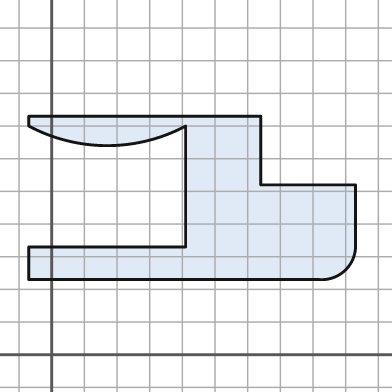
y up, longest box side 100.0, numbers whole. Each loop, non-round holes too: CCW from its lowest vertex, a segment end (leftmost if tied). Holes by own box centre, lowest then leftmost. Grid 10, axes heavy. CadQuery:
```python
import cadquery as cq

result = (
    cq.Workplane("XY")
    .moveTo(-7.0, 23.0)
    .lineTo(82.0, 23.0)
    .threePointArc((90.0, 26.0), (93.0, 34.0))
    .lineTo(93.0, 52.0)
    .lineTo(64.0, 52.0)
    .lineTo(64.0, 73.0)
    .lineTo(-7.0, 73.0)
    .lineTo(-7.0, 70.0)
    .threePointArc((17.0, 64.0), (41.0, 70.0))
    .lineTo(41.0, 33.0)
    .lineTo(-7.0, 33.0)
    .close()
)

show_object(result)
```